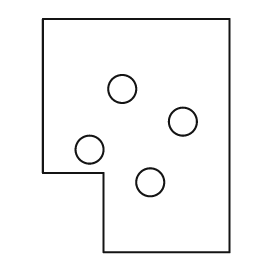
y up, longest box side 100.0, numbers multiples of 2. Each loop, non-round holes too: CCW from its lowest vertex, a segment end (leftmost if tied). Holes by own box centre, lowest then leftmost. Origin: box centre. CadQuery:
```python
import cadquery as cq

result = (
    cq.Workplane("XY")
    .moveTo(-14.0, -50.0)
    .lineTo(40.0, -50.0)
    .lineTo(40.0, 50.0)
    .lineTo(-40.0, 50.0)
    .lineTo(-40.0, -16.0)
    .lineTo(-14.0, -16.0)
    .close()
    .moveTo(6.0, -20.0)
    .circle(6.0)
    .moveTo(-20.0, -6.0)
    .circle(6.0)
    .moveTo(20.0, 6.0)
    .circle(6.0)
    .moveTo(-6.0, 20.0)
    .circle(6.0)
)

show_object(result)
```